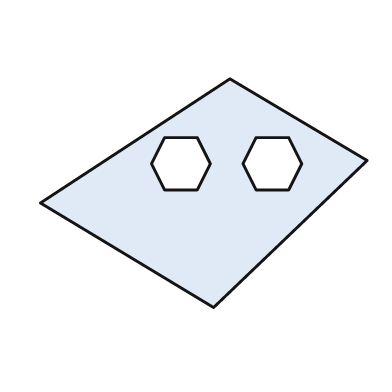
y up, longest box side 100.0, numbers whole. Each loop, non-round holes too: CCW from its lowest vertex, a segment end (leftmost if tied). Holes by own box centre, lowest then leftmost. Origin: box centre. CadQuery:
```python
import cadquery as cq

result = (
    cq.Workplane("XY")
    .moveTo(3.0, -35.0)
    .lineTo(50.0, 10.0)
    .lineTo(8.0, 35.0)
    .lineTo(-50.0, -3.0)
    .close()
    .moveTo(-12.0, 1.0)
    .lineTo(-2.0, 1.0)
    .lineTo(2.0, 9.0)
    .lineTo(-2.0, 17.0)
    .lineTo(-12.0, 17.0)
    .lineTo(-16.0, 9.0)
    .close()
    .moveTo(16.0, 1.0)
    .lineTo(26.0, 1.0)
    .lineTo(30.0, 9.0)
    .lineTo(26.0, 17.0)
    .lineTo(16.0, 17.0)
    .lineTo(12.0, 9.0)
    .close()
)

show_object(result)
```